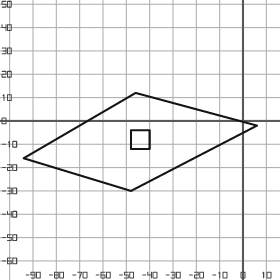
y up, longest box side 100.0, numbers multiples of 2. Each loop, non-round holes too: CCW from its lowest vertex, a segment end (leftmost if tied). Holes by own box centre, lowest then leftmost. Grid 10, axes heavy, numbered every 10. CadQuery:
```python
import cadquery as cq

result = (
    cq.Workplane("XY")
    .moveTo(-48.0, -30.0)
    .lineTo(6.0, -2.0)
    .lineTo(-46.0, 12.0)
    .lineTo(-94.0, -16.0)
    .close()
    .moveTo(-48.0, -12.0)
    .lineTo(-40.0, -12.0)
    .lineTo(-40.0, -4.0)
    .lineTo(-48.0, -4.0)
    .close()
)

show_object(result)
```